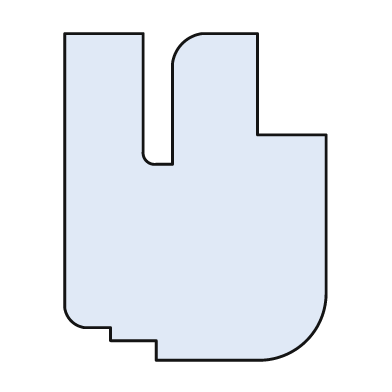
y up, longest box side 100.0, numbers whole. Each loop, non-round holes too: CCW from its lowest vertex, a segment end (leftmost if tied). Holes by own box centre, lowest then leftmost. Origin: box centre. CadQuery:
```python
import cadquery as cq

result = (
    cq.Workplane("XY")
    .moveTo(-12.0, -50.0)
    .lineTo(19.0, -50.0)
    .threePointArc((34.0, -44.0), (40.0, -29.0))
    .lineTo(40.0, 19.0)
    .lineTo(19.0, 19.0)
    .lineTo(19.0, 50.0)
    .lineTo(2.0, 50.0)
    .threePointArc((-4.0, 47.0), (-7.0, 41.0))
    .lineTo(-7.0, 10.0)
    .lineTo(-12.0, 10.0)
    .threePointArc((-15.0, 11.0), (-16.0, 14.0))
    .lineTo(-16.0, 50.0)
    .lineTo(-40.0, 50.0)
    .lineTo(-40.0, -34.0)
    .threePointArc((-38.0, -38.0), (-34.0, -40.0))
    .lineTo(-26.0, -40.0)
    .lineTo(-26.0, -44.0)
    .lineTo(-12.0, -44.0)
    .close()
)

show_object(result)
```